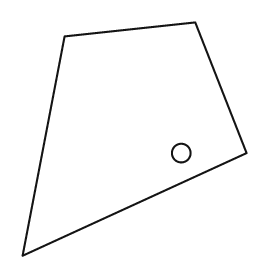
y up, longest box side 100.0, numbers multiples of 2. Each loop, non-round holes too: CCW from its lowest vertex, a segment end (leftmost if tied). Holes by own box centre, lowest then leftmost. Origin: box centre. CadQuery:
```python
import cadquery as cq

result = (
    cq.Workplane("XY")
    .moveTo(-48.0, -50.0)
    .lineTo(48.0, -6.0)
    .lineTo(26.0, 50.0)
    .lineTo(-30.0, 44.0)
    .close()
    .moveTo(20.0, -6.0)
    .circle(4.0)
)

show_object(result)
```